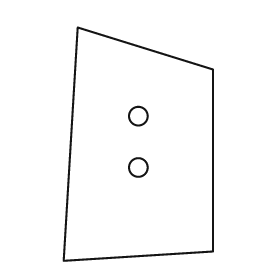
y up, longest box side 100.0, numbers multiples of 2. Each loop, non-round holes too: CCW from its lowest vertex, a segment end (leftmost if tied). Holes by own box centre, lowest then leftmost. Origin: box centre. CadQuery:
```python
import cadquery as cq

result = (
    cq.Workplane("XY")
    .moveTo(-32.0, -50.0)
    .lineTo(32.0, -46.0)
    .lineTo(32.0, 32.0)
    .lineTo(-26.0, 50.0)
    .close()
    .moveTo(0.0, -10.0)
    .circle(4.0)
    .moveTo(0.0, 12.0)
    .circle(4.0)
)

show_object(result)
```